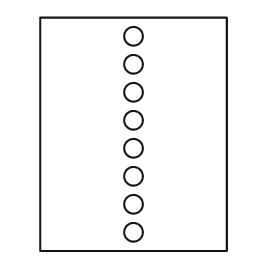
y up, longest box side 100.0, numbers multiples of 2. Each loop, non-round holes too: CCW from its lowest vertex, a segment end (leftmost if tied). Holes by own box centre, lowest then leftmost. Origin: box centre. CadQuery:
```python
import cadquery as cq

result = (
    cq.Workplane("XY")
    .moveTo(-40.0, -50.0)
    .lineTo(40.0, -50.0)
    .lineTo(40.0, 50.0)
    .lineTo(-40.0, 50.0)
    .close()
    .moveTo(0.0, -42.0)
    .circle(4.0)
    .moveTo(0.0, -30.0)
    .circle(4.0)
    .moveTo(0.0, -18.0)
    .circle(4.0)
    .moveTo(0.0, -6.0)
    .circle(4.0)
    .moveTo(0.0, 6.0)
    .circle(4.0)
    .moveTo(0.0, 18.0)
    .circle(4.0)
    .moveTo(0.0, 30.0)
    .circle(4.0)
    .moveTo(0.0, 42.0)
    .circle(4.0)
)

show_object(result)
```